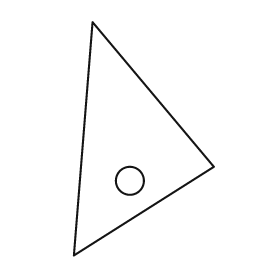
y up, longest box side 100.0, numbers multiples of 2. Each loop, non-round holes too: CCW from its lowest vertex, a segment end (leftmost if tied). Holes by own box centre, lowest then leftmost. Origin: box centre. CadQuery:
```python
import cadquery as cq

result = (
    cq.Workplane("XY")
    .moveTo(-30.0, -50.0)
    .lineTo(30.0, -12.0)
    .lineTo(-22.0, 50.0)
    .close()
    .moveTo(-6.0, -18.0)
    .circle(6.0)
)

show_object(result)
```